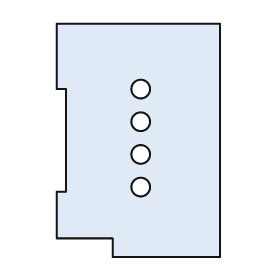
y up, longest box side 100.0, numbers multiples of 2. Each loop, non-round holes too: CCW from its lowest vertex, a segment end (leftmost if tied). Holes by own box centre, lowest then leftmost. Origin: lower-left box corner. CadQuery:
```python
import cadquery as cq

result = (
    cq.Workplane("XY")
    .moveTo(24.0, 0.0)
    .lineTo(70.0, 0.0)
    .lineTo(70.0, 100.0)
    .lineTo(0.0, 100.0)
    .lineTo(0.0, 72.0)
    .lineTo(4.0, 72.0)
    .lineTo(4.0, 28.0)
    .lineTo(0.0, 28.0)
    .lineTo(0.0, 8.0)
    .lineTo(24.0, 8.0)
    .close()
    .moveTo(36.0, 30.0)
    .circle(4.0)
    .moveTo(36.0, 44.0)
    .circle(4.0)
    .moveTo(36.0, 58.0)
    .circle(4.0)
    .moveTo(36.0, 72.0)
    .circle(4.0)
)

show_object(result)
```